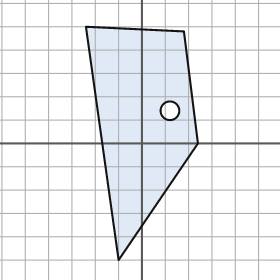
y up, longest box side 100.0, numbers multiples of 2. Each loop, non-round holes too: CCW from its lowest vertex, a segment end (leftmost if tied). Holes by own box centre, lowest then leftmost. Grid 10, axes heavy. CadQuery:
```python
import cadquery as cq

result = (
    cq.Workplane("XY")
    .moveTo(-10.0, -50.0)
    .lineTo(24.0, 0.0)
    .lineTo(18.0, 48.0)
    .lineTo(-24.0, 50.0)
    .close()
    .moveTo(12.0, 14.0)
    .circle(4.0)
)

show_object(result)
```